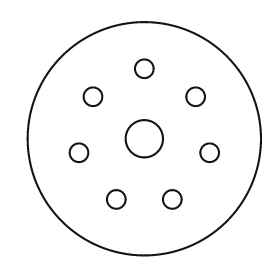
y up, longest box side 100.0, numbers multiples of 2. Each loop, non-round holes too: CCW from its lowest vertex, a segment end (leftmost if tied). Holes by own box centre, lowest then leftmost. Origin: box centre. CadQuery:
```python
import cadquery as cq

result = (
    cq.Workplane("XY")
    .moveTo(0.0, 0.0)
    .circle(50.0)
    .moveTo(-12.0, -26.0)
    .circle(4.0)
    .moveTo(12.0, -26.0)
    .circle(4.0)
    .moveTo(-28.0, -6.0)
    .circle(4.0)
    .moveTo(28.0, -6.0)
    .circle(4.0)
    .moveTo(0.0, 0.0)
    .circle(8.0)
    .moveTo(-22.0, 18.0)
    .circle(4.0)
    .moveTo(22.0, 18.0)
    .circle(4.0)
    .moveTo(0.0, 30.0)
    .circle(4.0)
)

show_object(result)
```